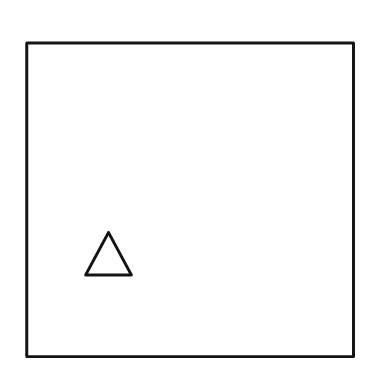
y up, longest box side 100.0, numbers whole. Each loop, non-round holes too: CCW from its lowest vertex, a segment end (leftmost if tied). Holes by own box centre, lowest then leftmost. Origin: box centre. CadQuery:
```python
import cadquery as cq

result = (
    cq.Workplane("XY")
    .moveTo(-50.0, -48.0)
    .lineTo(50.0, -48.0)
    .lineTo(50.0, 48.0)
    .lineTo(-50.0, 48.0)
    .close()
    .moveTo(-32.0, -23.0)
    .lineTo(-18.0, -23.0)
    .lineTo(-25.0, -10.0)
    .close()
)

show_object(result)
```